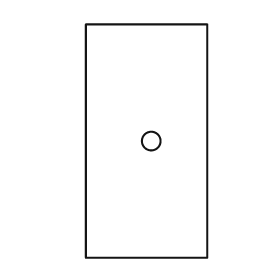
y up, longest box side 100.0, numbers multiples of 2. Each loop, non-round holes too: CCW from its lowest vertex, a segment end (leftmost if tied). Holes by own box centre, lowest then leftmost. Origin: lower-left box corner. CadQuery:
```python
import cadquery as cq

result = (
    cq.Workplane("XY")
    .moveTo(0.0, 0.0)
    .lineTo(52.0, 0.0)
    .lineTo(52.0, 100.0)
    .lineTo(0.0, 100.0)
    .close()
    .moveTo(28.0, 50.0)
    .circle(4.0)
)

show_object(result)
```